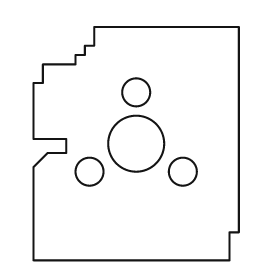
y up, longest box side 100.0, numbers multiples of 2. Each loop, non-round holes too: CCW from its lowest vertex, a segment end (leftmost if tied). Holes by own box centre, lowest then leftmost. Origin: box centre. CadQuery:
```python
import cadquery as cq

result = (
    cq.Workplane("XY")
    .moveTo(-44.0, -50.0)
    .lineTo(40.0, -50.0)
    .lineTo(40.0, -38.0)
    .lineTo(44.0, -38.0)
    .lineTo(44.0, 50.0)
    .lineTo(-18.0, 50.0)
    .lineTo(-18.0, 42.0)
    .lineTo(-22.0, 42.0)
    .lineTo(-22.0, 38.0)
    .lineTo(-26.0, 38.0)
    .lineTo(-26.0, 34.0)
    .lineTo(-40.0, 34.0)
    .lineTo(-40.0, 26.0)
    .lineTo(-44.0, 26.0)
    .lineTo(-44.0, 2.0)
    .lineTo(-30.0, 2.0)
    .lineTo(-30.0, -4.0)
    .lineTo(-38.0, -4.0)
    .lineTo(-44.0, -10.0)
    .close()
    .moveTo(-20.0, -12.0)
    .circle(6.0)
    .moveTo(20.0, -12.0)
    .circle(6.0)
    .moveTo(0.0, 0.0)
    .circle(12.0)
    .moveTo(0.0, 22.0)
    .circle(6.0)
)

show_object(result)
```